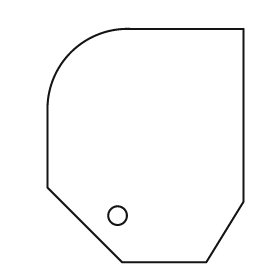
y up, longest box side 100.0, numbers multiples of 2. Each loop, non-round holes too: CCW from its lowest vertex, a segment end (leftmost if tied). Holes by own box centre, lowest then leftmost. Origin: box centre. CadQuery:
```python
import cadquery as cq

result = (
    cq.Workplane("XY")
    .moveTo(-10.0, -50.0)
    .lineTo(26.0, -50.0)
    .lineTo(42.0, -24.0)
    .lineTo(42.0, 50.0)
    .lineTo(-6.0, 50.0)
    .threePointArc((-32.0, 40.0), (-42.0, 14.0))
    .lineTo(-42.0, -18.0)
    .close()
    .moveTo(-12.0, -30.0)
    .circle(4.0)
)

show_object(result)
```